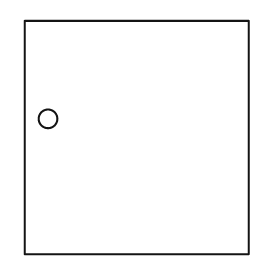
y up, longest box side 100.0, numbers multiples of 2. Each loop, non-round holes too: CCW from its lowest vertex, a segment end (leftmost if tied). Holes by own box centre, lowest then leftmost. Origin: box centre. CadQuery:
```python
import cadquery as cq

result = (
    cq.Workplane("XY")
    .moveTo(-48.0, -50.0)
    .lineTo(48.0, -50.0)
    .lineTo(48.0, 50.0)
    .lineTo(-48.0, 50.0)
    .close()
    .moveTo(-38.0, 8.0)
    .circle(4.0)
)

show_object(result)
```